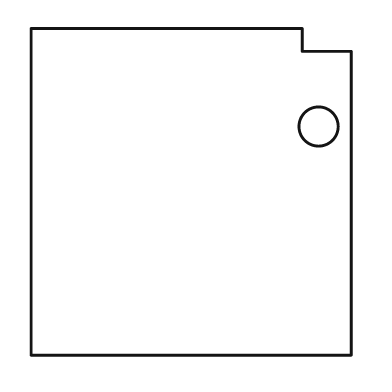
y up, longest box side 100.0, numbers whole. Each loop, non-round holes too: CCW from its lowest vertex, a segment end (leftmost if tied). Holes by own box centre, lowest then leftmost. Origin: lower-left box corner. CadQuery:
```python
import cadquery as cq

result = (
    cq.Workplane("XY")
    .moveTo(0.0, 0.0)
    .lineTo(98.0, 0.0)
    .lineTo(98.0, 93.0)
    .lineTo(83.0, 93.0)
    .lineTo(83.0, 100.0)
    .lineTo(0.0, 100.0)
    .close()
    .moveTo(88.0, 70.0)
    .circle(6.0)
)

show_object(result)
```